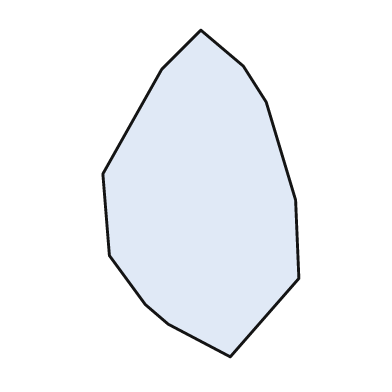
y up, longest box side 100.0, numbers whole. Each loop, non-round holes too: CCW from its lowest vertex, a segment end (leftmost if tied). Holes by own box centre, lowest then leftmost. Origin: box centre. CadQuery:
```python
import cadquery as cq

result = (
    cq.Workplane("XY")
    .moveTo(9.0, -50.0)
    .lineTo(30.0, -26.0)
    .lineTo(29.0, -2.0)
    .lineTo(20.0, 28.0)
    .lineTo(13.0, 39.0)
    .lineTo(0.0, 50.0)
    .lineTo(-12.0, 38.0)
    .lineTo(-30.0, 6.0)
    .lineTo(-28.0, -19.0)
    .lineTo(-17.0, -34.0)
    .lineTo(-10.0, -40.0)
    .close()
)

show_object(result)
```